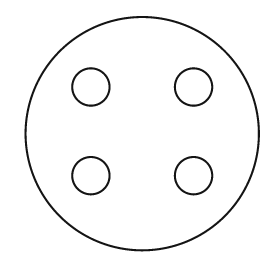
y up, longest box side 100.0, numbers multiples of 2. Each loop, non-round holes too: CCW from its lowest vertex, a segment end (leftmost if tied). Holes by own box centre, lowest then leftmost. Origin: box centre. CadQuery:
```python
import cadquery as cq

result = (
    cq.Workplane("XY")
    .moveTo(0.0, 0.0)
    .circle(50.0)
    .moveTo(-22.0, -18.0)
    .circle(8.0)
    .moveTo(22.0, -18.0)
    .circle(8.0)
    .moveTo(-22.0, 20.0)
    .circle(8.0)
    .moveTo(22.0, 20.0)
    .circle(8.0)
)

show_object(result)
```